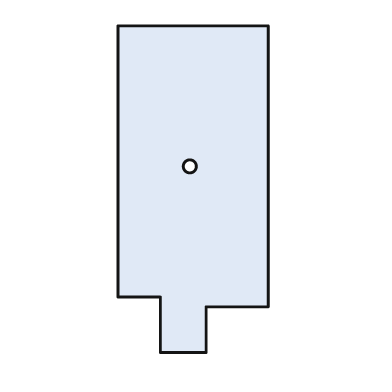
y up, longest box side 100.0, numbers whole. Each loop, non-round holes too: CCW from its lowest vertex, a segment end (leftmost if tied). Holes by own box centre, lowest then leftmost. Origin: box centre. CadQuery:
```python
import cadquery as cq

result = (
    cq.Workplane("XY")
    .moveTo(-10.0, -50.0)
    .lineTo(4.0, -50.0)
    .lineTo(4.0, -36.0)
    .lineTo(23.0, -36.0)
    .lineTo(23.0, 50.0)
    .lineTo(-23.0, 50.0)
    .lineTo(-23.0, -33.0)
    .lineTo(-10.0, -33.0)
    .close()
    .moveTo(-1.0, 7.0)
    .circle(2.0)
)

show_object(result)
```